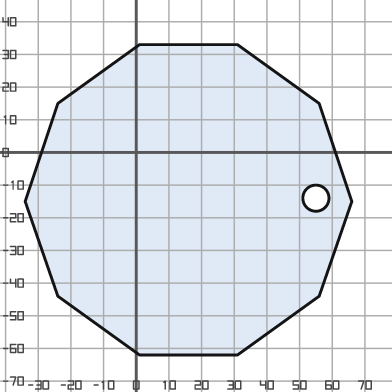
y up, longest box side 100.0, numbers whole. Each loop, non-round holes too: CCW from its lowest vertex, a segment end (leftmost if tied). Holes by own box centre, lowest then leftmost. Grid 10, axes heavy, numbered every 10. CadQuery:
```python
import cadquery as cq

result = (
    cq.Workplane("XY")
    .moveTo(1.0, -62.0)
    .lineTo(31.0, -62.0)
    .lineTo(56.0, -44.0)
    .lineTo(66.0, -15.0)
    .lineTo(56.0, 15.0)
    .lineTo(31.0, 33.0)
    .lineTo(1.0, 33.0)
    .lineTo(-24.0, 15.0)
    .lineTo(-34.0, -15.0)
    .lineTo(-24.0, -44.0)
    .close()
    .moveTo(55.0, -14.0)
    .circle(4.0)
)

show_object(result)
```